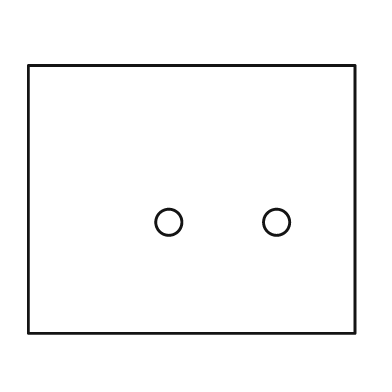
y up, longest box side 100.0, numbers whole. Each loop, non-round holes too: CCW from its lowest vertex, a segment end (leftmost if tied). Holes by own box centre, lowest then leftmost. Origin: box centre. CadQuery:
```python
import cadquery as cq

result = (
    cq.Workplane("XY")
    .moveTo(-50.0, -41.0)
    .lineTo(50.0, -41.0)
    .lineTo(50.0, 41.0)
    .lineTo(-50.0, 41.0)
    .close()
    .moveTo(-7.0, -7.0)
    .circle(4.0)
    .moveTo(26.0, -7.0)
    .circle(4.0)
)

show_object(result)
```